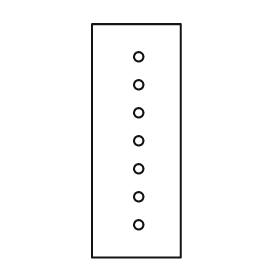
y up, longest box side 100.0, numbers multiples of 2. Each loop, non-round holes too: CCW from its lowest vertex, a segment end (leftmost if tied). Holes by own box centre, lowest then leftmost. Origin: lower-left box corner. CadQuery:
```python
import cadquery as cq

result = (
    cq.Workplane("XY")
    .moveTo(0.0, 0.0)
    .lineTo(38.0, 0.0)
    .lineTo(38.0, 100.0)
    .lineTo(0.0, 100.0)
    .close()
    .moveTo(20.0, 14.0)
    .circle(2.0)
    .moveTo(20.0, 26.0)
    .circle(2.0)
    .moveTo(20.0, 38.0)
    .circle(2.0)
    .moveTo(20.0, 50.0)
    .circle(2.0)
    .moveTo(20.0, 62.0)
    .circle(2.0)
    .moveTo(20.0, 74.0)
    .circle(2.0)
    .moveTo(20.0, 86.0)
    .circle(2.0)
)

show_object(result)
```